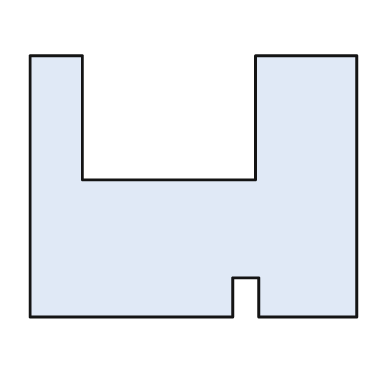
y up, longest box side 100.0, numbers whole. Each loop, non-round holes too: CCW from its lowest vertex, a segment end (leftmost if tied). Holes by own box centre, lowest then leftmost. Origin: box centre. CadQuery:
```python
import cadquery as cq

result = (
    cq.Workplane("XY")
    .moveTo(-50.0, -40.0)
    .lineTo(12.0, -40.0)
    .lineTo(12.0, -28.0)
    .lineTo(20.0, -28.0)
    .lineTo(20.0, -40.0)
    .lineTo(50.0, -40.0)
    .lineTo(50.0, 40.0)
    .lineTo(19.0, 40.0)
    .lineTo(19.0, 2.0)
    .lineTo(-34.0, 2.0)
    .lineTo(-34.0, 40.0)
    .lineTo(-50.0, 40.0)
    .close()
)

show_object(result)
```